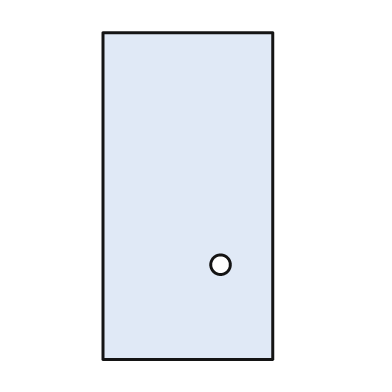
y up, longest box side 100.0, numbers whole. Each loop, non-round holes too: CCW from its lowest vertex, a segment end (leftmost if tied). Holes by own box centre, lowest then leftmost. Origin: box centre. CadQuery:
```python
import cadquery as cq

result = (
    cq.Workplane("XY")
    .moveTo(-26.0, -50.0)
    .lineTo(26.0, -50.0)
    .lineTo(26.0, 50.0)
    .lineTo(-26.0, 50.0)
    .close()
    .moveTo(10.0, -21.0)
    .circle(3.0)
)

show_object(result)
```